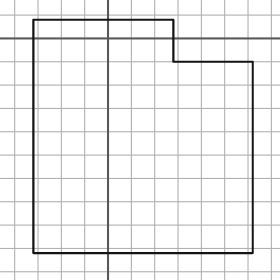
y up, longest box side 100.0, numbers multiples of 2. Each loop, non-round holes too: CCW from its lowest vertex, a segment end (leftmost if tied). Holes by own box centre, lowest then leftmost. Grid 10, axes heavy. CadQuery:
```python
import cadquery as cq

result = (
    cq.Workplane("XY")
    .moveTo(-32.0, -92.0)
    .lineTo(62.0, -92.0)
    .lineTo(62.0, -10.0)
    .lineTo(28.0, -10.0)
    .lineTo(28.0, 8.0)
    .lineTo(-32.0, 8.0)
    .close()
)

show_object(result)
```